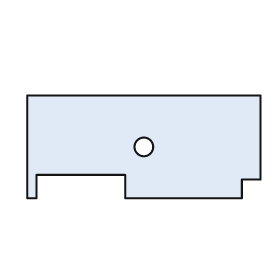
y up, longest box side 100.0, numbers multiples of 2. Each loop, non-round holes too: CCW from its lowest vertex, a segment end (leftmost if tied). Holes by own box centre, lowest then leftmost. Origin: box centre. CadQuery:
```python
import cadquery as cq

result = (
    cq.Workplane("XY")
    .moveTo(-50.0, -22.0)
    .lineTo(-46.0, -22.0)
    .lineTo(-46.0, -12.0)
    .lineTo(-8.0, -12.0)
    .lineTo(-8.0, -22.0)
    .lineTo(42.0, -22.0)
    .lineTo(42.0, -14.0)
    .lineTo(50.0, -14.0)
    .lineTo(50.0, 22.0)
    .lineTo(-50.0, 22.0)
    .close()
    .moveTo(0.0, 0.0)
    .circle(4.0)
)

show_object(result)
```